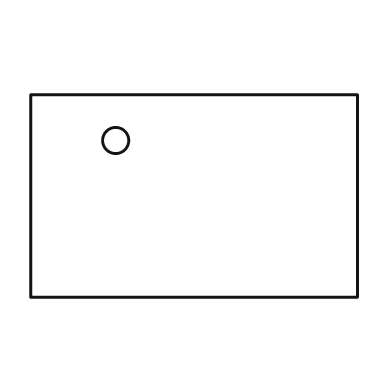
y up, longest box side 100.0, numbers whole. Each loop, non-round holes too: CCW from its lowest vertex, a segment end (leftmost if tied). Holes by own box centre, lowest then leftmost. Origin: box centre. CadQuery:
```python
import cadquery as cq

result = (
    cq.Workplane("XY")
    .moveTo(-50.0, -31.0)
    .lineTo(50.0, -31.0)
    .lineTo(50.0, 31.0)
    .lineTo(-50.0, 31.0)
    .close()
    .moveTo(-24.0, 17.0)
    .circle(4.0)
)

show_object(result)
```